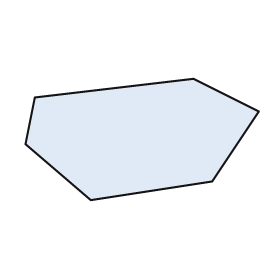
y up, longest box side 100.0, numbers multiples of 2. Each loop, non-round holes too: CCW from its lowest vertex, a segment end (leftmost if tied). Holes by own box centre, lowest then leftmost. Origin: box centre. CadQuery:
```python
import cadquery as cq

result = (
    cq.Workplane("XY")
    .moveTo(-22.0, -26.0)
    .lineTo(30.0, -18.0)
    .lineTo(50.0, 12.0)
    .lineTo(22.0, 26.0)
    .lineTo(-46.0, 18.0)
    .lineTo(-50.0, -2.0)
    .close()
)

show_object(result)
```